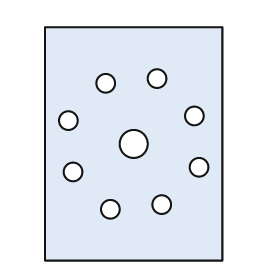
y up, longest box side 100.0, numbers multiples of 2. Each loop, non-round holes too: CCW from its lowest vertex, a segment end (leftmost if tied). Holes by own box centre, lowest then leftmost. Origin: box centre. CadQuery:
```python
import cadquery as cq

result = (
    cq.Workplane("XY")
    .moveTo(-38.0, -50.0)
    .lineTo(38.0, -50.0)
    .lineTo(38.0, 50.0)
    .lineTo(-38.0, 50.0)
    .close()
    .moveTo(-10.0, -28.0)
    .circle(4.0)
    .moveTo(12.0, -26.0)
    .circle(4.0)
    .moveTo(-26.0, -12.0)
    .circle(4.0)
    .moveTo(28.0, -10.0)
    .circle(4.0)
    .moveTo(0.0, 0.0)
    .circle(6.0)
    .moveTo(-28.0, 10.0)
    .circle(4.0)
    .moveTo(26.0, 12.0)
    .circle(4.0)
    .moveTo(-12.0, 26.0)
    .circle(4.0)
    .moveTo(10.0, 28.0)
    .circle(4.0)
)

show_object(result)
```